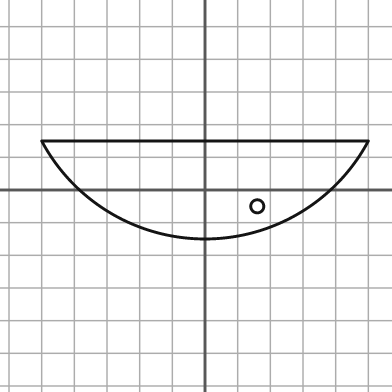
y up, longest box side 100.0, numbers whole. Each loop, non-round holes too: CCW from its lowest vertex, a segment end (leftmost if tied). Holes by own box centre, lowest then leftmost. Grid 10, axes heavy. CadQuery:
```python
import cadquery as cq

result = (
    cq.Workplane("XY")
    .moveTo(-50.0, 15.0)
    .threePointArc((0.0, -15.0), (50.0, 15.0))
    .close()
    .moveTo(16.0, -5.0)
    .circle(2.0)
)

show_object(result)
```